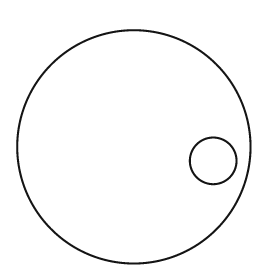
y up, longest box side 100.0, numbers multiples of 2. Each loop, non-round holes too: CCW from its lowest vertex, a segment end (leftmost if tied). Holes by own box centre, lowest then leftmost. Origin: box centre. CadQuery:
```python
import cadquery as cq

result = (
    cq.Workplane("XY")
    .moveTo(0.0, 0.0)
    .circle(50.0)
    .moveTo(34.0, -6.0)
    .circle(10.0)
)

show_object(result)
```